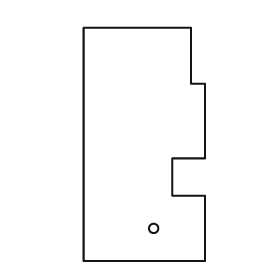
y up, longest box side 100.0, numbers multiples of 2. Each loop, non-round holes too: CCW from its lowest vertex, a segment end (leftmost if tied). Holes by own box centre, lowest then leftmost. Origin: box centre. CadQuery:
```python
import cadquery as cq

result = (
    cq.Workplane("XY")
    .moveTo(-26.0, -50.0)
    .lineTo(26.0, -50.0)
    .lineTo(26.0, -22.0)
    .lineTo(12.0, -22.0)
    .lineTo(12.0, -6.0)
    .lineTo(26.0, -6.0)
    .lineTo(26.0, 26.0)
    .lineTo(20.0, 26.0)
    .lineTo(20.0, 50.0)
    .lineTo(-26.0, 50.0)
    .close()
    .moveTo(4.0, -36.0)
    .circle(2.0)
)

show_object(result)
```